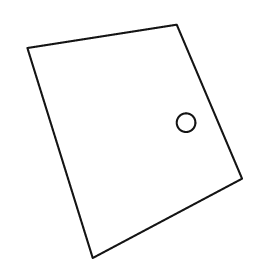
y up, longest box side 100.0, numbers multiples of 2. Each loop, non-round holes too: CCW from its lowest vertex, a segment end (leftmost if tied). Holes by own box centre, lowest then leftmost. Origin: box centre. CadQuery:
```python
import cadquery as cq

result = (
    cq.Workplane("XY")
    .moveTo(-18.0, -50.0)
    .lineTo(46.0, -16.0)
    .lineTo(18.0, 50.0)
    .lineTo(-46.0, 40.0)
    .close()
    .moveTo(22.0, 8.0)
    .circle(4.0)
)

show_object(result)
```